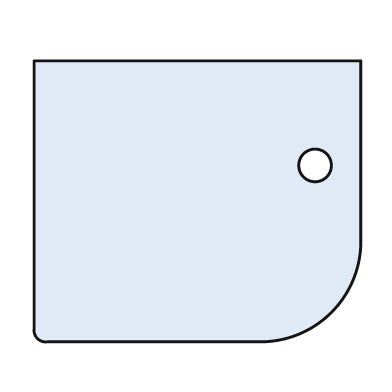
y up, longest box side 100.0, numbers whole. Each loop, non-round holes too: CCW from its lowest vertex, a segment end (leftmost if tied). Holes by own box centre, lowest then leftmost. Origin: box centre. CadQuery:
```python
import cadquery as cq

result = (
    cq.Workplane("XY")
    .moveTo(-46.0, -43.0)
    .lineTo(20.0, -43.0)
    .threePointArc((41.0, -34.0), (50.0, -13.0))
    .lineTo(50.0, 43.0)
    .lineTo(-50.0, 43.0)
    .lineTo(-50.0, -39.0)
    .threePointArc((-49.0, -42.0), (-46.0, -43.0))
    .close()
    .moveTo(36.0, 11.0)
    .circle(5.0)
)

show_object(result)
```